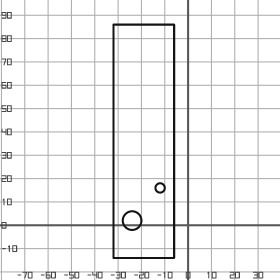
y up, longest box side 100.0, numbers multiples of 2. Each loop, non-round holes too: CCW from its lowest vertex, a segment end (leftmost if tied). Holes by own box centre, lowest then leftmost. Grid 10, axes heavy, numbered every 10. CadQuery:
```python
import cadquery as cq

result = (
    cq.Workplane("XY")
    .moveTo(-32.0, -14.0)
    .lineTo(-6.0, -14.0)
    .lineTo(-6.0, 86.0)
    .lineTo(-32.0, 86.0)
    .close()
    .moveTo(-24.0, 2.0)
    .circle(4.0)
    .moveTo(-12.0, 16.0)
    .circle(2.0)
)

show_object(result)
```